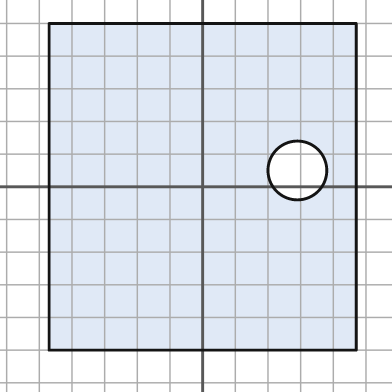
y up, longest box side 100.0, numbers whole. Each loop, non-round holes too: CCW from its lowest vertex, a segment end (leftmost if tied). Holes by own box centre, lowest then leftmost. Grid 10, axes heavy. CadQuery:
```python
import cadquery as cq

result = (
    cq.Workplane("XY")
    .moveTo(-47.0, -50.0)
    .lineTo(47.0, -50.0)
    .lineTo(47.0, 50.0)
    .lineTo(-47.0, 50.0)
    .close()
    .moveTo(29.0, 5.0)
    .circle(9.0)
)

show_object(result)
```